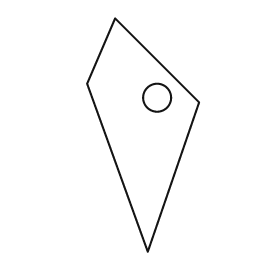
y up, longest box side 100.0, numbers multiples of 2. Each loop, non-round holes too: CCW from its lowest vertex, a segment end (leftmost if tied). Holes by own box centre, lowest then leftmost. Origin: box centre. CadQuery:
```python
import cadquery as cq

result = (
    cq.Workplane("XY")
    .moveTo(2.0, -50.0)
    .lineTo(24.0, 14.0)
    .lineTo(-12.0, 50.0)
    .lineTo(-24.0, 22.0)
    .close()
    .moveTo(6.0, 16.0)
    .circle(6.0)
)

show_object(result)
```